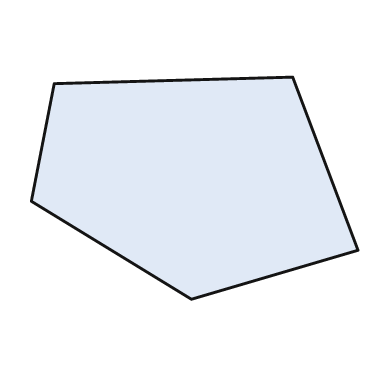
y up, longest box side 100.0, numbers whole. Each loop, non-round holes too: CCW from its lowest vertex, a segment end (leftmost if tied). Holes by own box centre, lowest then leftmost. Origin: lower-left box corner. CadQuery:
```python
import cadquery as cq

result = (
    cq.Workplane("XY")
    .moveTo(49.0, 0.0)
    .lineTo(100.0, 15.0)
    .lineTo(80.0, 68.0)
    .lineTo(7.0, 66.0)
    .lineTo(0.0, 30.0)
    .close()
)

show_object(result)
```